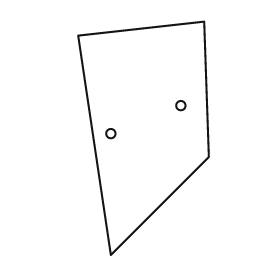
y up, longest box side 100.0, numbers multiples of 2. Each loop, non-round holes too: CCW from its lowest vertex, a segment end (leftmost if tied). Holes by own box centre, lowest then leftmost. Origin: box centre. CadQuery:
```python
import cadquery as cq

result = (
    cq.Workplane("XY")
    .moveTo(-14.0, -50.0)
    .lineTo(28.0, -8.0)
    .lineTo(26.0, 50.0)
    .lineTo(-28.0, 44.0)
    .close()
    .moveTo(-14.0, 2.0)
    .circle(2.0)
    .moveTo(16.0, 14.0)
    .circle(2.0)
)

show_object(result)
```